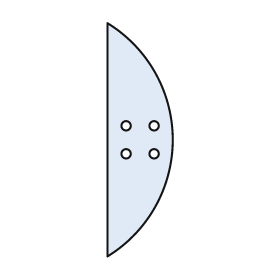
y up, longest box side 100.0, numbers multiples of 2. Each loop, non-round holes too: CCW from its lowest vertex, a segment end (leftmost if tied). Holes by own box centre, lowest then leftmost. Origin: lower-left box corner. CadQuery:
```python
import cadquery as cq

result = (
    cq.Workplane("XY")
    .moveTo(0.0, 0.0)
    .threePointArc((28.0, 50.0), (0.0, 100.0))
    .close()
    .moveTo(8.0, 44.0)
    .circle(2.0)
    .moveTo(20.0, 44.0)
    .circle(2.0)
    .moveTo(8.0, 56.0)
    .circle(2.0)
    .moveTo(20.0, 56.0)
    .circle(2.0)
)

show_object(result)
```